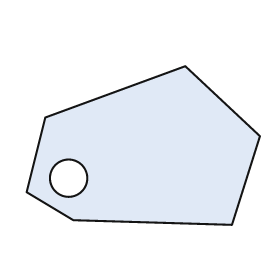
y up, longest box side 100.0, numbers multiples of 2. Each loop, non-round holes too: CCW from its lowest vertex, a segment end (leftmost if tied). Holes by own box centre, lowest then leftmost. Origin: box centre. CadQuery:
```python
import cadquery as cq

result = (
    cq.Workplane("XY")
    .moveTo(38.0, -34.0)
    .lineTo(50.0, 4.0)
    .lineTo(18.0, 34.0)
    .lineTo(-42.0, 12.0)
    .lineTo(-50.0, -20.0)
    .lineTo(-30.0, -32.0)
    .close()
    .moveTo(-32.0, -14.0)
    .circle(8.0)
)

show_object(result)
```